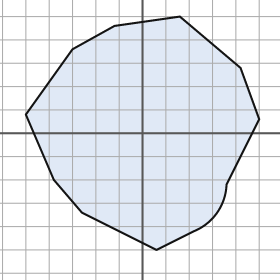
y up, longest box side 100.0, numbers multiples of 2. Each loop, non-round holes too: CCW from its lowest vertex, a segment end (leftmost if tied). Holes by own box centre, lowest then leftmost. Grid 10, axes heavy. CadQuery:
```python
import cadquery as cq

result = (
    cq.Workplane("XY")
    .moveTo(6.0, -50.0)
    .lineTo(22.0, -42.0)
    .threePointArc((32.0, -34.0), (36.0, -22.0))
    .lineTo(50.0, 6.0)
    .lineTo(42.0, 28.0)
    .lineTo(16.0, 50.0)
    .lineTo(-12.0, 46.0)
    .lineTo(-30.0, 36.0)
    .lineTo(-50.0, 8.0)
    .lineTo(-38.0, -20.0)
    .lineTo(-26.0, -34.0)
    .close()
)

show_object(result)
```